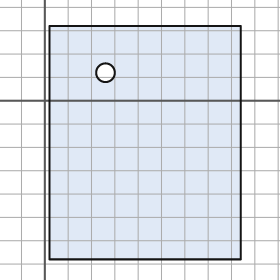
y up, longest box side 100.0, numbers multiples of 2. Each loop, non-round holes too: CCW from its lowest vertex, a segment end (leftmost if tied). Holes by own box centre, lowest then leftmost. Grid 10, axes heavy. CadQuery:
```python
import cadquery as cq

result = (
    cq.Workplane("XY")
    .moveTo(2.0, -68.0)
    .lineTo(84.0, -68.0)
    .lineTo(84.0, 32.0)
    .lineTo(2.0, 32.0)
    .close()
    .moveTo(26.0, 12.0)
    .circle(4.0)
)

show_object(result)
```